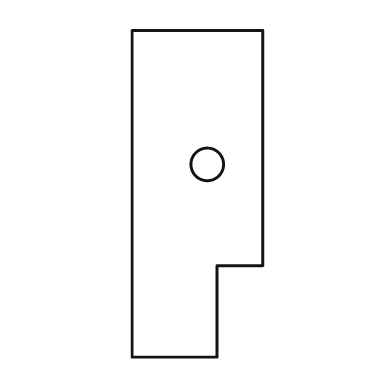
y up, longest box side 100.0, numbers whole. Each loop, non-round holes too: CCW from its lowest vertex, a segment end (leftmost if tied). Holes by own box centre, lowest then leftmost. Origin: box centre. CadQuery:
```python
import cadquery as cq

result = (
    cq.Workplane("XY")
    .moveTo(-20.0, -50.0)
    .lineTo(6.0, -50.0)
    .lineTo(6.0, -22.0)
    .lineTo(20.0, -22.0)
    .lineTo(20.0, 50.0)
    .lineTo(-20.0, 50.0)
    .close()
    .moveTo(3.0, 9.0)
    .circle(5.0)
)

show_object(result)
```